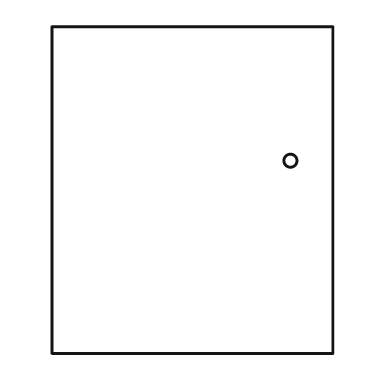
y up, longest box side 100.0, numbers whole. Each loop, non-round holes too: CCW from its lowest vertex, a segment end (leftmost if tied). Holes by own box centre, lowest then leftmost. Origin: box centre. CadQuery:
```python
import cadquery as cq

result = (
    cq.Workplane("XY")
    .moveTo(-43.0, -50.0)
    .lineTo(43.0, -50.0)
    .lineTo(43.0, 50.0)
    .lineTo(-43.0, 50.0)
    .close()
    .moveTo(30.0, 9.0)
    .circle(2.0)
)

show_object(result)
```